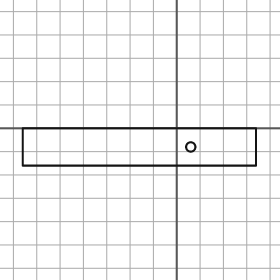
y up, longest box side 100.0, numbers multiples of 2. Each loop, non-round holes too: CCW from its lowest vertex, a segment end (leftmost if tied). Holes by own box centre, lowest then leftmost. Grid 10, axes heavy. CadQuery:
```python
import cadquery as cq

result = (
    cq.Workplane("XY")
    .moveTo(-66.0, -16.0)
    .lineTo(34.0, -16.0)
    .lineTo(34.0, 0.0)
    .lineTo(-66.0, 0.0)
    .close()
    .moveTo(6.0, -8.0)
    .circle(2.0)
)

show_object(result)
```